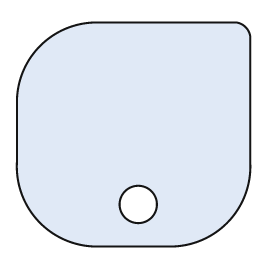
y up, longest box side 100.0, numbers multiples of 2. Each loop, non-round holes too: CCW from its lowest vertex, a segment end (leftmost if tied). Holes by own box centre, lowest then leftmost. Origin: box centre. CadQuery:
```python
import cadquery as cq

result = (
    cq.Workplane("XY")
    .moveTo(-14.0, -48.0)
    .lineTo(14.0, -48.0)
    .threePointArc((40.0, -38.0), (50.0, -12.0))
    .lineTo(50.0, 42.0)
    .threePointArc((48.0, 46.0), (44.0, 48.0))
    .lineTo(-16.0, 48.0)
    .threePointArc((-40.0, 38.0), (-50.0, 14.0))
    .lineTo(-50.0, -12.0)
    .threePointArc((-40.0, -38.0), (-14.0, -48.0))
    .close()
    .moveTo(2.0, -30.0)
    .circle(8.0)
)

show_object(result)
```